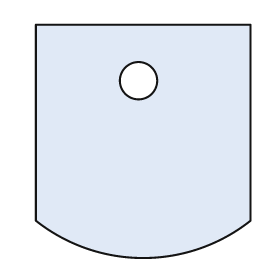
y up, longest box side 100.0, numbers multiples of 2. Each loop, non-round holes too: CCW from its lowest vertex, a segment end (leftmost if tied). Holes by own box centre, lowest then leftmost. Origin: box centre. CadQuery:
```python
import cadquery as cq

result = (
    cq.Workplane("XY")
    .moveTo(-46.0, -34.0)
    .threePointArc((0.0, -50.0), (46.0, -34.0))
    .lineTo(46.0, 50.0)
    .lineTo(-46.0, 50.0)
    .close()
    .moveTo(-2.0, 26.0)
    .circle(8.0)
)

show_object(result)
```